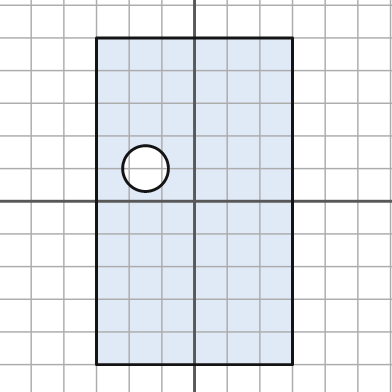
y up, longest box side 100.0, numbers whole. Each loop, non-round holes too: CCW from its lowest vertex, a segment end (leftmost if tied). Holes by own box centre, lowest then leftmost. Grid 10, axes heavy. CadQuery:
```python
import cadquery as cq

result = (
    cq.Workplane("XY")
    .moveTo(-30.0, -50.0)
    .lineTo(30.0, -50.0)
    .lineTo(30.0, 50.0)
    .lineTo(-30.0, 50.0)
    .close()
    .moveTo(-15.0, 10.0)
    .circle(7.0)
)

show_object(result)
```